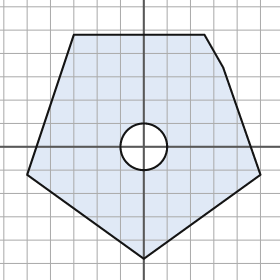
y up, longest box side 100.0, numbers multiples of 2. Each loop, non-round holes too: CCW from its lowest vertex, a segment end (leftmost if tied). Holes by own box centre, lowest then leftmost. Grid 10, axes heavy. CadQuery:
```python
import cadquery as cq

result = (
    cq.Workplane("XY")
    .moveTo(0.0, -48.0)
    .lineTo(50.0, -12.0)
    .lineTo(34.0, 34.0)
    .lineTo(26.0, 48.0)
    .lineTo(-30.0, 48.0)
    .lineTo(-50.0, -12.0)
    .close()
    .moveTo(0.0, 0.0)
    .circle(10.0)
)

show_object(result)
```